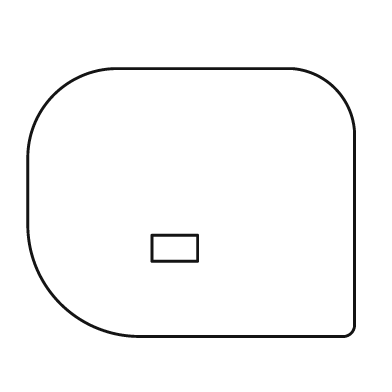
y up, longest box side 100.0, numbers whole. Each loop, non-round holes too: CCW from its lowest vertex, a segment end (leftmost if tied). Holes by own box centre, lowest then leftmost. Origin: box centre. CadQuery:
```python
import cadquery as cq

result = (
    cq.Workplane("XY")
    .moveTo(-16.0, -41.0)
    .lineTo(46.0, -41.0)
    .threePointArc((49.0, -40.0), (50.0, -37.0))
    .lineTo(50.0, 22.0)
    .threePointArc((44.0, 35.0), (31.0, 41.0))
    .lineTo(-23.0, 41.0)
    .threePointArc((-42.0, 33.0), (-50.0, 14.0))
    .lineTo(-50.0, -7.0)
    .threePointArc((-40.0, -31.0), (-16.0, -41.0))
    .close()
    .moveTo(-12.0, -18.0)
    .lineTo(2.0, -18.0)
    .lineTo(2.0, -10.0)
    .lineTo(-12.0, -10.0)
    .close()
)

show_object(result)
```